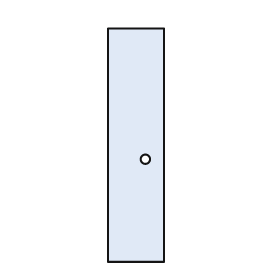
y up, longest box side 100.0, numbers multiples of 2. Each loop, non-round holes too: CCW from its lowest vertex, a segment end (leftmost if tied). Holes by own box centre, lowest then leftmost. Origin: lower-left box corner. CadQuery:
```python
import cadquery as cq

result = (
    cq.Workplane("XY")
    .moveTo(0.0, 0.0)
    .lineTo(24.0, 0.0)
    .lineTo(24.0, 100.0)
    .lineTo(0.0, 100.0)
    .close()
    .moveTo(16.0, 44.0)
    .circle(2.0)
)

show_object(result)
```